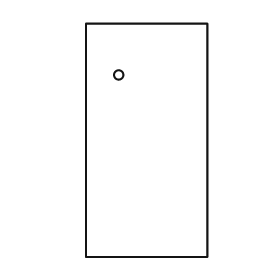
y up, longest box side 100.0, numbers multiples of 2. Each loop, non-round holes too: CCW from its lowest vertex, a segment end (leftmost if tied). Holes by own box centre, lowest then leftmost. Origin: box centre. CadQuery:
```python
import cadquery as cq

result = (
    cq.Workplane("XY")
    .moveTo(-26.0, -50.0)
    .lineTo(26.0, -50.0)
    .lineTo(26.0, 50.0)
    .lineTo(-26.0, 50.0)
    .close()
    .moveTo(-12.0, 28.0)
    .circle(2.0)
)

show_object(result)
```